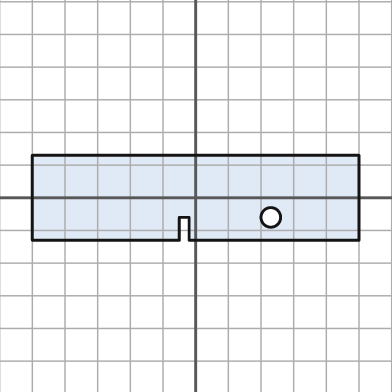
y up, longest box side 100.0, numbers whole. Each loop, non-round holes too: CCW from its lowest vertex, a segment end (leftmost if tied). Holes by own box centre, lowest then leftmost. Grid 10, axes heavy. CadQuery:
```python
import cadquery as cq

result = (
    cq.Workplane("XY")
    .moveTo(-50.0, -13.0)
    .lineTo(-5.0, -13.0)
    .lineTo(-5.0, -6.0)
    .lineTo(-2.0, -6.0)
    .lineTo(-2.0, -13.0)
    .lineTo(50.0, -13.0)
    .lineTo(50.0, 13.0)
    .lineTo(-50.0, 13.0)
    .close()
    .moveTo(23.0, -6.0)
    .circle(3.0)
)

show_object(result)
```